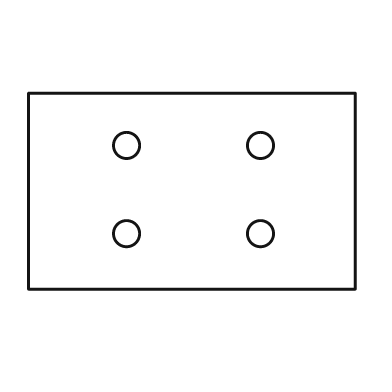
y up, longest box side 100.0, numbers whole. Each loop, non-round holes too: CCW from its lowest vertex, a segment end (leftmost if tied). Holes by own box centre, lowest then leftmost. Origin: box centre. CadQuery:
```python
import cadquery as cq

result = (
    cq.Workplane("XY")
    .moveTo(-50.0, -30.0)
    .lineTo(50.0, -30.0)
    .lineTo(50.0, 30.0)
    .lineTo(-50.0, 30.0)
    .close()
    .moveTo(-20.0, -13.0)
    .circle(4.0)
    .moveTo(21.0, -13.0)
    .circle(4.0)
    .moveTo(-20.0, 14.0)
    .circle(4.0)
    .moveTo(21.0, 14.0)
    .circle(4.0)
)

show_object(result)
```